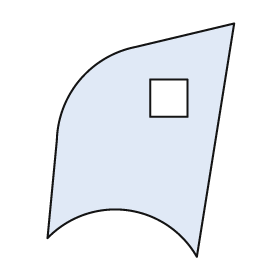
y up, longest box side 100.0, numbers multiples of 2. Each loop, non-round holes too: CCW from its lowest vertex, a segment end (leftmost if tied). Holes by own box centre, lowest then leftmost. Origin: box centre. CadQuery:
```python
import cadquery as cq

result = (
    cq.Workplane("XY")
    .moveTo(24.0, -50.0)
    .lineTo(40.0, 50.0)
    .lineTo(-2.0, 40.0)
    .threePointArc((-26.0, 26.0), (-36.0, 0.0))
    .lineTo(-40.0, -42.0)
    .threePointArc((-6.0, -30.0), (24.0, -50.0))
    .close()
    .moveTo(4.0, 10.0)
    .lineTo(20.0, 10.0)
    .lineTo(20.0, 26.0)
    .lineTo(4.0, 26.0)
    .close()
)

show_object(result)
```